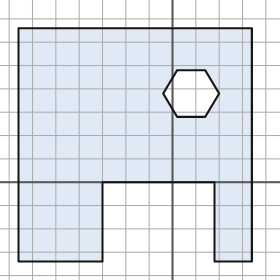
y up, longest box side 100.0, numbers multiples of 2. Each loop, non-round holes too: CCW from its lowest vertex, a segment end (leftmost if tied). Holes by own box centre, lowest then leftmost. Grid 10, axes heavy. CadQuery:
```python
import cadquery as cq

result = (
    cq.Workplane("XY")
    .moveTo(-66.0, -34.0)
    .lineTo(-30.0, -34.0)
    .lineTo(-30.0, 0.0)
    .lineTo(18.0, 0.0)
    .lineTo(18.0, -34.0)
    .lineTo(34.0, -34.0)
    .lineTo(34.0, 66.0)
    .lineTo(-66.0, 66.0)
    .close()
    .moveTo(2.0, 28.0)
    .lineTo(14.0, 28.0)
    .lineTo(20.0, 38.0)
    .lineTo(14.0, 48.0)
    .lineTo(2.0, 48.0)
    .lineTo(-4.0, 38.0)
    .close()
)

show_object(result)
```